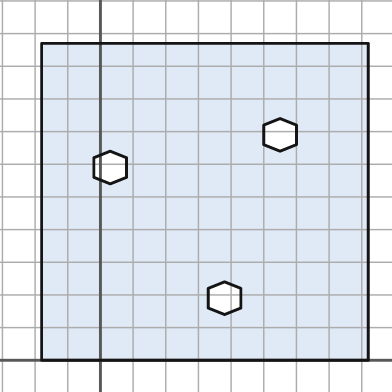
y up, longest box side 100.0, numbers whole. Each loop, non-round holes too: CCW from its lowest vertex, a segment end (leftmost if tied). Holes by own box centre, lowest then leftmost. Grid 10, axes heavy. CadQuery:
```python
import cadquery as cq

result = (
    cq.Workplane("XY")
    .moveTo(-18.0, 0.0)
    .lineTo(82.0, 0.0)
    .lineTo(82.0, 97.0)
    .lineTo(-18.0, 97.0)
    .close()
    .moveTo(38.0, 14.0)
    .lineTo(43.0, 16.0)
    .lineTo(43.0, 22.0)
    .lineTo(38.0, 24.0)
    .lineTo(33.0, 22.0)
    .lineTo(33.0, 16.0)
    .close()
    .moveTo(3.0, 54.0)
    .lineTo(8.0, 56.0)
    .lineTo(8.0, 62.0)
    .lineTo(3.0, 64.0)
    .lineTo(-2.0, 62.0)
    .lineTo(-2.0, 56.0)
    .close()
    .moveTo(55.0, 64.0)
    .lineTo(60.0, 66.0)
    .lineTo(60.0, 72.0)
    .lineTo(55.0, 74.0)
    .lineTo(50.0, 72.0)
    .lineTo(50.0, 66.0)
    .close()
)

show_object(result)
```